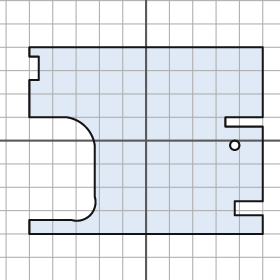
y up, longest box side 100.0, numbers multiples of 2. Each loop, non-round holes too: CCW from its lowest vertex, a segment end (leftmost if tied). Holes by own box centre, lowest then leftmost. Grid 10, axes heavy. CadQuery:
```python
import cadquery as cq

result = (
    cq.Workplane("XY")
    .moveTo(-50.0, -40.0)
    .lineTo(50.0, -40.0)
    .lineTo(50.0, -32.0)
    .lineTo(38.0, -32.0)
    .lineTo(38.0, -26.0)
    .lineTo(50.0, -26.0)
    .lineTo(50.0, 6.0)
    .lineTo(34.0, 6.0)
    .lineTo(34.0, 10.0)
    .lineTo(50.0, 10.0)
    .lineTo(50.0, 40.0)
    .lineTo(-50.0, 40.0)
    .lineTo(-50.0, 36.0)
    .lineTo(-46.0, 36.0)
    .lineTo(-46.0, 26.0)
    .lineTo(-50.0, 26.0)
    .lineTo(-50.0, 10.0)
    .lineTo(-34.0, 10.0)
    .threePointArc((-26.0, 6.0), (-22.0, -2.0))
    .lineTo(-22.0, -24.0)
    .threePointArc((-24.0, -32.0), (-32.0, -34.0))
    .lineTo(-50.0, -34.0)
    .close()
    .moveTo(38.0, -2.0)
    .circle(2.0)
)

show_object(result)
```